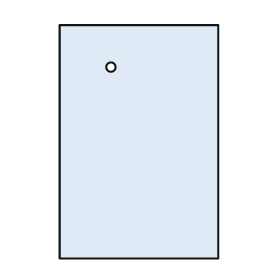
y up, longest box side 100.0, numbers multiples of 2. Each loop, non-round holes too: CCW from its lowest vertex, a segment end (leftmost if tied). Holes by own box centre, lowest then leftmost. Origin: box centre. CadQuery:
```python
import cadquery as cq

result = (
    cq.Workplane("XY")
    .moveTo(-34.0, -50.0)
    .lineTo(34.0, -50.0)
    .lineTo(34.0, 50.0)
    .lineTo(-34.0, 50.0)
    .close()
    .moveTo(-12.0, 32.0)
    .circle(2.0)
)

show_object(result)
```